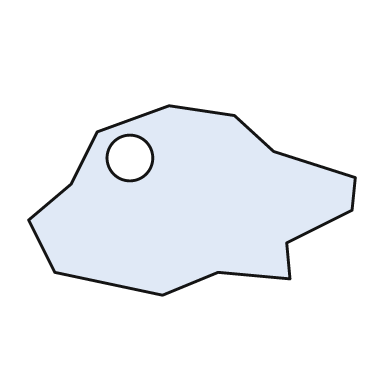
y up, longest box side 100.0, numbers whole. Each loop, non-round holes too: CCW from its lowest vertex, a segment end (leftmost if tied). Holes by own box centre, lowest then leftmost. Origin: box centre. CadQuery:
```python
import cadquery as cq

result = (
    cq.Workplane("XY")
    .moveTo(-9.0, -29.0)
    .lineTo(8.0, -22.0)
    .lineTo(30.0, -24.0)
    .lineTo(29.0, -13.0)
    .lineTo(49.0, -3.0)
    .lineTo(50.0, 7.0)
    .lineTo(25.0, 15.0)
    .lineTo(13.0, 26.0)
    .lineTo(-7.0, 29.0)
    .lineTo(-29.0, 21.0)
    .lineTo(-37.0, 5.0)
    .lineTo(-50.0, -6.0)
    .lineTo(-42.0, -22.0)
    .close()
    .moveTo(-19.0, 13.0)
    .circle(7.0)
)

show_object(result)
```